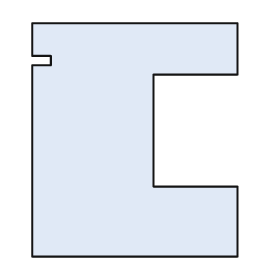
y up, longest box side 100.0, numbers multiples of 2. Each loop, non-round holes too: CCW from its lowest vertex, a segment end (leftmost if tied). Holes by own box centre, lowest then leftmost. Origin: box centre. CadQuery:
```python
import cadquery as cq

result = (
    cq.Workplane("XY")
    .moveTo(-44.0, -50.0)
    .lineTo(44.0, -50.0)
    .lineTo(44.0, -20.0)
    .lineTo(8.0, -20.0)
    .lineTo(8.0, 28.0)
    .lineTo(44.0, 28.0)
    .lineTo(44.0, 50.0)
    .lineTo(-44.0, 50.0)
    .lineTo(-44.0, 36.0)
    .lineTo(-36.0, 36.0)
    .lineTo(-36.0, 32.0)
    .lineTo(-44.0, 32.0)
    .close()
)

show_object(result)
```